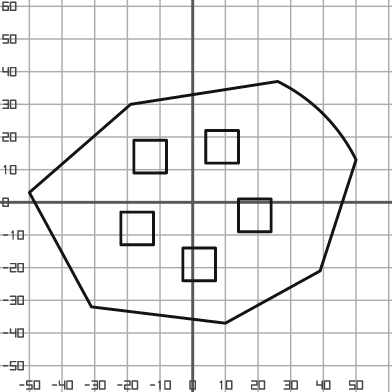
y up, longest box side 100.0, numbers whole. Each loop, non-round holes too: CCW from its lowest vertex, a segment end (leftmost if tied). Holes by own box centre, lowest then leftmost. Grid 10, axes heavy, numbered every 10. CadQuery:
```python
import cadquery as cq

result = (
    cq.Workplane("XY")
    .moveTo(10.0, -37.0)
    .lineTo(39.0, -21.0)
    .lineTo(50.0, 13.0)
    .threePointArc((40.0, 27.0), (26.0, 37.0))
    .lineTo(-19.0, 30.0)
    .lineTo(-50.0, 3.0)
    .lineTo(-31.0, -32.0)
    .close()
    .moveTo(-3.0, -24.0)
    .lineTo(7.0, -24.0)
    .lineTo(7.0, -14.0)
    .lineTo(-3.0, -14.0)
    .close()
    .moveTo(-22.0, -13.0)
    .lineTo(-12.0, -13.0)
    .lineTo(-12.0, -3.0)
    .lineTo(-22.0, -3.0)
    .close()
    .moveTo(14.0, -9.0)
    .lineTo(24.0, -9.0)
    .lineTo(24.0, 1.0)
    .lineTo(14.0, 1.0)
    .close()
    .moveTo(-18.0, 9.0)
    .lineTo(-8.0, 9.0)
    .lineTo(-8.0, 19.0)
    .lineTo(-18.0, 19.0)
    .close()
    .moveTo(4.0, 12.0)
    .lineTo(14.0, 12.0)
    .lineTo(14.0, 22.0)
    .lineTo(4.0, 22.0)
    .close()
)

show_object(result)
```